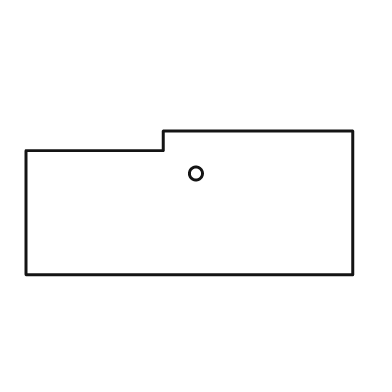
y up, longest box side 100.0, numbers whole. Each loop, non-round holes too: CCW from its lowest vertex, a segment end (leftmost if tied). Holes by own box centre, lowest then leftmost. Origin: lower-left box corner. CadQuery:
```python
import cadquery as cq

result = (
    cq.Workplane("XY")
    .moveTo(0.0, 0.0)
    .lineTo(100.0, 0.0)
    .lineTo(100.0, 44.0)
    .lineTo(42.0, 44.0)
    .lineTo(42.0, 38.0)
    .lineTo(0.0, 38.0)
    .close()
    .moveTo(52.0, 31.0)
    .circle(2.0)
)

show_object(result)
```